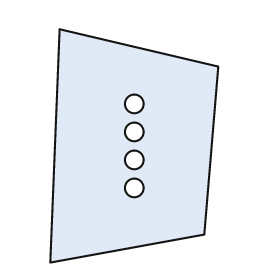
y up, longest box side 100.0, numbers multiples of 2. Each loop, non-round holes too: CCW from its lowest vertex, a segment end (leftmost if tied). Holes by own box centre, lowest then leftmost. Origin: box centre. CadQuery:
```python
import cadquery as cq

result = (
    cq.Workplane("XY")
    .moveTo(-36.0, -50.0)
    .lineTo(30.0, -38.0)
    .lineTo(36.0, 34.0)
    .lineTo(-32.0, 50.0)
    .close()
    .moveTo(0.0, -18.0)
    .circle(4.0)
    .moveTo(0.0, -6.0)
    .circle(4.0)
    .moveTo(0.0, 6.0)
    .circle(4.0)
    .moveTo(0.0, 18.0)
    .circle(4.0)
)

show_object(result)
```